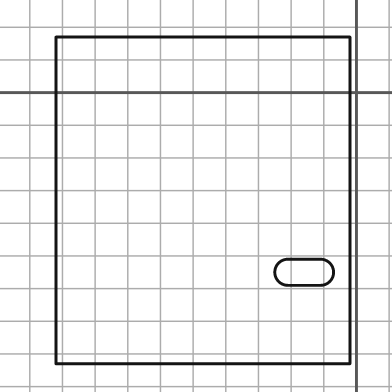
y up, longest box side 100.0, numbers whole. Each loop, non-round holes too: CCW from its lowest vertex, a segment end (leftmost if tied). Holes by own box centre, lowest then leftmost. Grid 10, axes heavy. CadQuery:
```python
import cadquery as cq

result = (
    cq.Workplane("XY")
    .moveTo(-92.0, -83.0)
    .lineTo(-2.0, -83.0)
    .lineTo(-2.0, 17.0)
    .lineTo(-92.0, 17.0)
    .close()
    .moveTo(-21.0, -59.0)
    .lineTo(-11.0, -59.0)
    .threePointArc((-7.0, -55.0), (-11.0, -51.0))
    .lineTo(-21.0, -51.0)
    .threePointArc((-25.0, -55.0), (-21.0, -59.0))
    .close()
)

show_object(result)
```